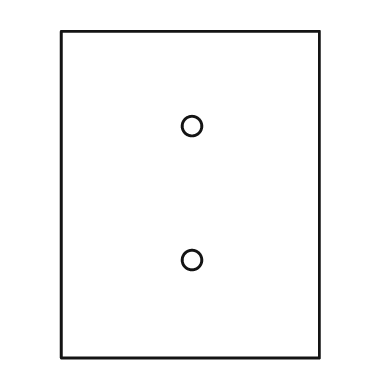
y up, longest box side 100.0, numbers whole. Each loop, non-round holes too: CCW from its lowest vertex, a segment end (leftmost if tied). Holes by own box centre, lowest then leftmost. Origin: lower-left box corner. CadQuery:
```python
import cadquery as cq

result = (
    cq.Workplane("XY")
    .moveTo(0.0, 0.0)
    .lineTo(79.0, 0.0)
    .lineTo(79.0, 100.0)
    .lineTo(0.0, 100.0)
    .close()
    .moveTo(40.0, 30.0)
    .circle(3.0)
    .moveTo(40.0, 71.0)
    .circle(3.0)
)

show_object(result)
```